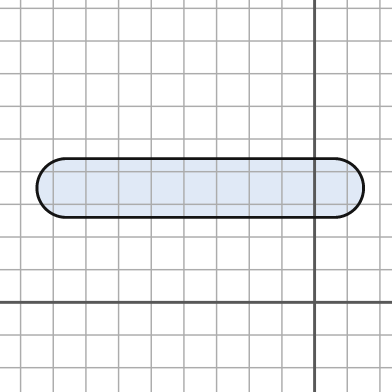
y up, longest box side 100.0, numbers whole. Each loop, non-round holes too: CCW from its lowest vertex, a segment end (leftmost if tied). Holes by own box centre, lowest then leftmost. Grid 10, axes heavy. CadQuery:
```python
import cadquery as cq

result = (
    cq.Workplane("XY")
    .moveTo(-76.0, 26.0)
    .lineTo(6.0, 26.0)
    .threePointArc((15.0, 35.0), (6.0, 44.0))
    .lineTo(-76.0, 44.0)
    .threePointArc((-85.0, 35.0), (-76.0, 26.0))
    .close()
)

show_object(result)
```